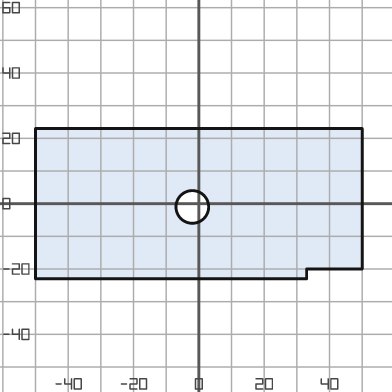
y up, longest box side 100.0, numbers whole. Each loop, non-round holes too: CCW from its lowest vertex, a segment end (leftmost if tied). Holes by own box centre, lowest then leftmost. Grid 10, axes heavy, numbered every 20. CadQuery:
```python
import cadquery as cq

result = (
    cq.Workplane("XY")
    .moveTo(-50.0, -23.0)
    .lineTo(33.0, -23.0)
    .lineTo(33.0, -20.0)
    .lineTo(50.0, -20.0)
    .lineTo(50.0, 23.0)
    .lineTo(-50.0, 23.0)
    .close()
    .moveTo(-2.0, -1.0)
    .circle(5.0)
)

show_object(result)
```